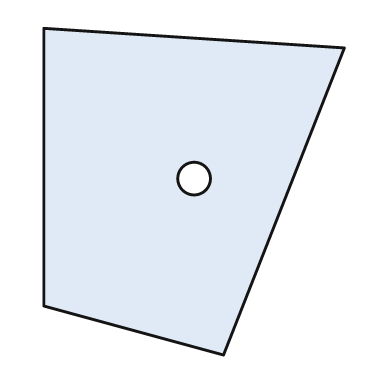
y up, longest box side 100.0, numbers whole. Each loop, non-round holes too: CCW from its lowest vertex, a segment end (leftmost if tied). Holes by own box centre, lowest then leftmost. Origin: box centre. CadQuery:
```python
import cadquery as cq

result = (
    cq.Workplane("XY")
    .moveTo(9.0, -50.0)
    .lineTo(46.0, 44.0)
    .lineTo(-46.0, 50.0)
    .lineTo(-46.0, -35.0)
    .close()
    .moveTo(0.0, 4.0)
    .circle(5.0)
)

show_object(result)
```